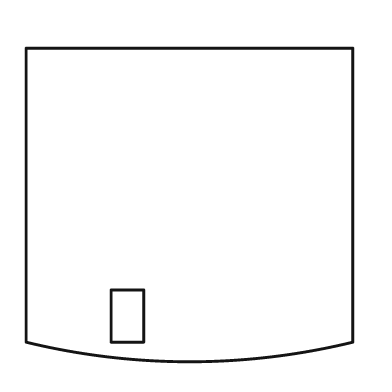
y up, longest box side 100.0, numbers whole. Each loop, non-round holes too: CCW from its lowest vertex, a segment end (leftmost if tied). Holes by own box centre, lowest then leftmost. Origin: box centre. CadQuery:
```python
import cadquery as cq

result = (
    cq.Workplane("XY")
    .moveTo(-50.0, -42.0)
    .threePointArc((0.0, -48.0), (50.0, -42.0))
    .lineTo(50.0, 48.0)
    .lineTo(-50.0, 48.0)
    .close()
    .moveTo(-24.0, -42.0)
    .lineTo(-14.0, -42.0)
    .lineTo(-14.0, -26.0)
    .lineTo(-24.0, -26.0)
    .close()
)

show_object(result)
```